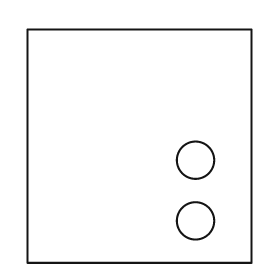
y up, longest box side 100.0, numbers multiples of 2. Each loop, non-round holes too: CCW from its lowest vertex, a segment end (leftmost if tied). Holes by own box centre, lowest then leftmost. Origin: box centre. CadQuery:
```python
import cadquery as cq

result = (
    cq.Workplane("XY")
    .moveTo(-48.0, -50.0)
    .lineTo(48.0, -50.0)
    .lineTo(48.0, 50.0)
    .lineTo(-48.0, 50.0)
    .close()
    .moveTo(24.0, -32.0)
    .circle(8.0)
    .moveTo(24.0, -6.0)
    .circle(8.0)
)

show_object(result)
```